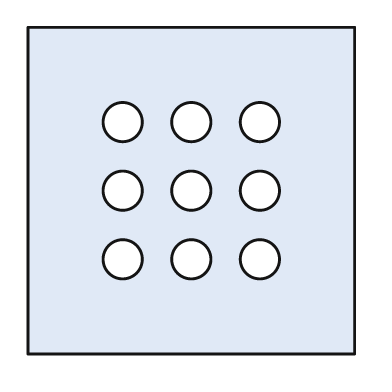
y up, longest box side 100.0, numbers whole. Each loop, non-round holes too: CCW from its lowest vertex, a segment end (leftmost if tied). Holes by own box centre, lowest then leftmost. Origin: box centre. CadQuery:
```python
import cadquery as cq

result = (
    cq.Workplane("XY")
    .moveTo(-50.0, -50.0)
    .lineTo(50.0, -50.0)
    .lineTo(50.0, 50.0)
    .lineTo(-50.0, 50.0)
    .close()
    .moveTo(-21.0, -21.0)
    .circle(6.0)
    .moveTo(0.0, -21.0)
    .circle(6.0)
    .moveTo(21.0, -21.0)
    .circle(6.0)
    .moveTo(-21.0, 0.0)
    .circle(6.0)
    .moveTo(0.0, 0.0)
    .circle(6.0)
    .moveTo(21.0, 0.0)
    .circle(6.0)
    .moveTo(-21.0, 21.0)
    .circle(6.0)
    .moveTo(0.0, 21.0)
    .circle(6.0)
    .moveTo(21.0, 21.0)
    .circle(6.0)
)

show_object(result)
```